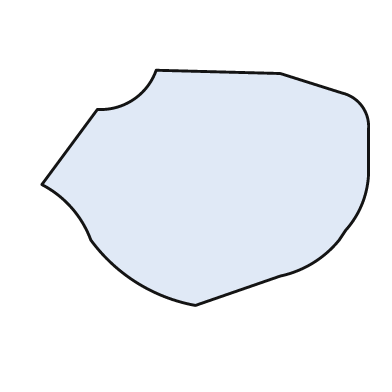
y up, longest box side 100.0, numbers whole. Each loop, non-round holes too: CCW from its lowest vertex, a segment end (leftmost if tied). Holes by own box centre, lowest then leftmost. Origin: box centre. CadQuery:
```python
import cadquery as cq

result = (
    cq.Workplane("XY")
    .moveTo(-3.0, -36.0)
    .lineTo(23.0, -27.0)
    .threePointArc((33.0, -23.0), (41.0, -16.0))
    .lineTo(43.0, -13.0)
    .threePointArc((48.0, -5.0), (50.0, 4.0))
    .lineTo(50.0, 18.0)
    .threePointArc((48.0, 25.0), (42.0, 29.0))
    .lineTo(23.0, 35.0)
    .lineTo(-15.0, 36.0)
    .threePointArc((-22.0, 27.0), (-33.0, 24.0))
    .lineTo(-50.0, 1.0)
    .threePointArc((-41.0, -6.0), (-35.0, -16.0))
    .threePointArc((-21.0, -29.0), (-3.0, -36.0))
    .close()
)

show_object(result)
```